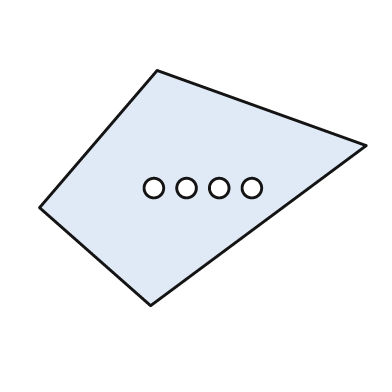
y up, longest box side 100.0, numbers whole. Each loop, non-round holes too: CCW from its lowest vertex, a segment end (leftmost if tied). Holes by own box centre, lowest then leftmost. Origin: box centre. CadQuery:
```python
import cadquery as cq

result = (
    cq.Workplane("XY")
    .moveTo(-16.0, -36.0)
    .lineTo(50.0, 13.0)
    .lineTo(-14.0, 36.0)
    .lineTo(-50.0, -6.0)
    .close()
    .moveTo(-15.0, 0.0)
    .circle(3.0)
    .moveTo(-5.0, 0.0)
    .circle(3.0)
    .moveTo(5.0, 0.0)
    .circle(3.0)
    .moveTo(15.0, 0.0)
    .circle(3.0)
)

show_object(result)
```